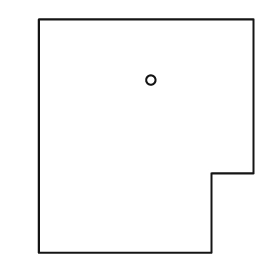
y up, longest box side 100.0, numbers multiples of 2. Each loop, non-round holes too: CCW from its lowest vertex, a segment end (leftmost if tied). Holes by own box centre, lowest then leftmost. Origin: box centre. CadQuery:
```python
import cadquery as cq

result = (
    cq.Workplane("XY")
    .moveTo(-46.0, -50.0)
    .lineTo(28.0, -50.0)
    .lineTo(28.0, -16.0)
    .lineTo(46.0, -16.0)
    .lineTo(46.0, 50.0)
    .lineTo(-46.0, 50.0)
    .close()
    .moveTo(2.0, 24.0)
    .circle(2.0)
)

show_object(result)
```